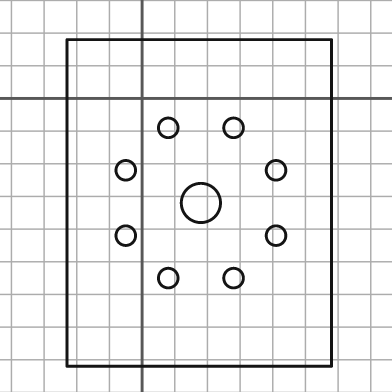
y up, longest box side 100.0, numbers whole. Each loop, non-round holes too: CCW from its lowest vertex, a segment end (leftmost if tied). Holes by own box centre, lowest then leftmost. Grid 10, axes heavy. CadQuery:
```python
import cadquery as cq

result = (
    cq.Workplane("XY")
    .moveTo(-23.0, -82.0)
    .lineTo(58.0, -82.0)
    .lineTo(58.0, 18.0)
    .lineTo(-23.0, 18.0)
    .close()
    .moveTo(8.0, -55.0)
    .circle(3.0)
    .moveTo(28.0, -55.0)
    .circle(3.0)
    .moveTo(-5.0, -42.0)
    .circle(3.0)
    .moveTo(41.0, -42.0)
    .circle(3.0)
    .moveTo(18.0, -32.0)
    .circle(6.0)
    .moveTo(-5.0, -22.0)
    .circle(3.0)
    .moveTo(41.0, -22.0)
    .circle(3.0)
    .moveTo(8.0, -9.0)
    .circle(3.0)
    .moveTo(28.0, -9.0)
    .circle(3.0)
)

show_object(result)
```